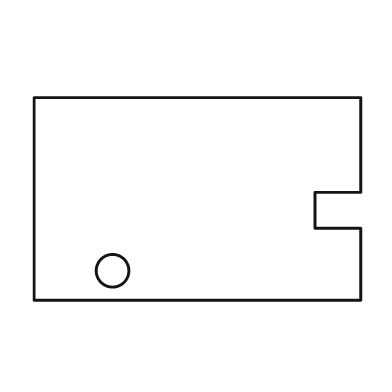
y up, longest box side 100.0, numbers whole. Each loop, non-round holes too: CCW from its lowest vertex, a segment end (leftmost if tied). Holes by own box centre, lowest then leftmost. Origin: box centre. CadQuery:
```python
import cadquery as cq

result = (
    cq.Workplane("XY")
    .moveTo(-50.0, -31.0)
    .lineTo(50.0, -31.0)
    .lineTo(50.0, -9.0)
    .lineTo(36.0, -9.0)
    .lineTo(36.0, 2.0)
    .lineTo(50.0, 2.0)
    .lineTo(50.0, 31.0)
    .lineTo(-50.0, 31.0)
    .close()
    .moveTo(-26.0, -22.0)
    .circle(5.0)
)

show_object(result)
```